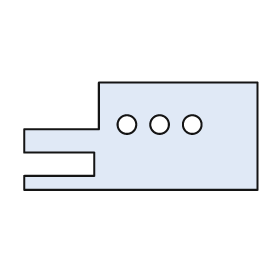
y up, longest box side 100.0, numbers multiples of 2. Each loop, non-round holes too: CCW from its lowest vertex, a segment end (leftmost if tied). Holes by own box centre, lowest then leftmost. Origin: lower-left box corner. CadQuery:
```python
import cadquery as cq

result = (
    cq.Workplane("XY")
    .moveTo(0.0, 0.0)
    .lineTo(100.0, 0.0)
    .lineTo(100.0, 46.0)
    .lineTo(32.0, 46.0)
    .lineTo(32.0, 26.0)
    .lineTo(0.0, 26.0)
    .lineTo(0.0, 16.0)
    .lineTo(30.0, 16.0)
    .lineTo(30.0, 6.0)
    .lineTo(0.0, 6.0)
    .close()
    .moveTo(44.0, 28.0)
    .circle(4.0)
    .moveTo(58.0, 28.0)
    .circle(4.0)
    .moveTo(72.0, 28.0)
    .circle(4.0)
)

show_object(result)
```